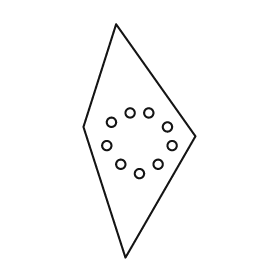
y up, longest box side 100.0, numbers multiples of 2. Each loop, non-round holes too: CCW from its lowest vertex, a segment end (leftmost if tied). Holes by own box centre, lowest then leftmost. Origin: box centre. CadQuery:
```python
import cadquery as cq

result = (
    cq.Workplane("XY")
    .moveTo(-6.0, -50.0)
    .lineTo(24.0, 2.0)
    .lineTo(-10.0, 50.0)
    .lineTo(-24.0, 6.0)
    .close()
    .moveTo(0.0, -14.0)
    .circle(2.0)
    .moveTo(-8.0, -10.0)
    .circle(2.0)
    .moveTo(8.0, -10.0)
    .circle(2.0)
    .moveTo(-14.0, -2.0)
    .circle(2.0)
    .moveTo(14.0, -2.0)
    .circle(2.0)
    .moveTo(12.0, 6.0)
    .circle(2.0)
    .moveTo(-12.0, 8.0)
    .circle(2.0)
    .moveTo(-4.0, 12.0)
    .circle(2.0)
    .moveTo(4.0, 12.0)
    .circle(2.0)
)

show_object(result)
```